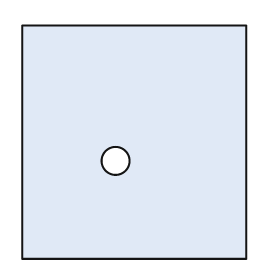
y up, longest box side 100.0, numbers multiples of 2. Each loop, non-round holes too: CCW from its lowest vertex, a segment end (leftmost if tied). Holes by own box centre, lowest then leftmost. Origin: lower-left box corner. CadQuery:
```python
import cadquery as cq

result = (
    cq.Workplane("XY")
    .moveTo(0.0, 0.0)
    .lineTo(96.0, 0.0)
    .lineTo(96.0, 100.0)
    .lineTo(0.0, 100.0)
    .close()
    .moveTo(40.0, 42.0)
    .circle(6.0)
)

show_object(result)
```